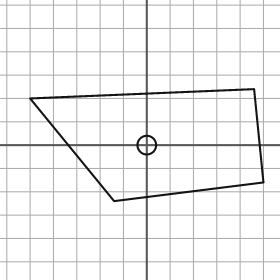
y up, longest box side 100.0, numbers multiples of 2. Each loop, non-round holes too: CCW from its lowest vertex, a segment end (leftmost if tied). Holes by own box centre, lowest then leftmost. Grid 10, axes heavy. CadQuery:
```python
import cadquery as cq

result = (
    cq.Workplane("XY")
    .moveTo(-14.0, -24.0)
    .lineTo(50.0, -16.0)
    .lineTo(46.0, 24.0)
    .lineTo(-50.0, 20.0)
    .close()
    .moveTo(0.0, 0.0)
    .circle(4.0)
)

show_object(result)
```